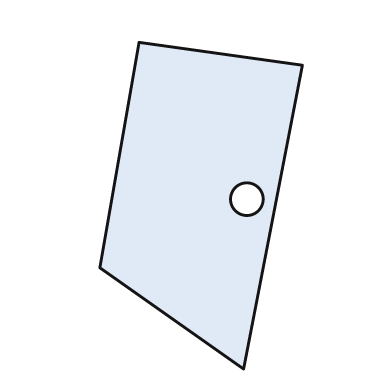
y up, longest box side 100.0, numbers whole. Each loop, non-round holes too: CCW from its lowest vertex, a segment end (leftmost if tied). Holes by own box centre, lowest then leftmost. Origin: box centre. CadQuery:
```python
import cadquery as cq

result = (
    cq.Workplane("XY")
    .moveTo(13.0, -50.0)
    .lineTo(31.0, 43.0)
    .lineTo(-19.0, 50.0)
    .lineTo(-31.0, -19.0)
    .close()
    .moveTo(14.0, 2.0)
    .circle(5.0)
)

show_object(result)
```